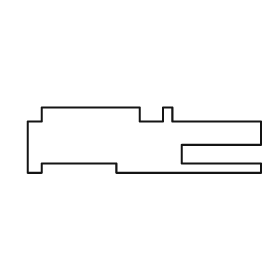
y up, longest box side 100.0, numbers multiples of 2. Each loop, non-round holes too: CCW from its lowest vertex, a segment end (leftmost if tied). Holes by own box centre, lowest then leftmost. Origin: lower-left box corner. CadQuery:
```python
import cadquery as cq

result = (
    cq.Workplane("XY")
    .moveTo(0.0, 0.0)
    .lineTo(6.0, 0.0)
    .lineTo(6.0, 4.0)
    .lineTo(38.0, 4.0)
    .lineTo(38.0, 0.0)
    .lineTo(100.0, 0.0)
    .lineTo(100.0, 4.0)
    .lineTo(66.0, 4.0)
    .lineTo(66.0, 12.0)
    .lineTo(100.0, 12.0)
    .lineTo(100.0, 22.0)
    .lineTo(62.0, 22.0)
    .lineTo(62.0, 28.0)
    .lineTo(58.0, 28.0)
    .lineTo(58.0, 22.0)
    .lineTo(48.0, 22.0)
    .lineTo(48.0, 28.0)
    .lineTo(6.0, 28.0)
    .lineTo(6.0, 22.0)
    .lineTo(0.0, 22.0)
    .close()
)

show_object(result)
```